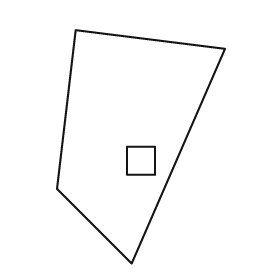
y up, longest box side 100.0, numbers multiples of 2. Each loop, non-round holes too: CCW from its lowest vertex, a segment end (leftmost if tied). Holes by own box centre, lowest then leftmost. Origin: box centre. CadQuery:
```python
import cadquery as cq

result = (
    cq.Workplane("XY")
    .moveTo(-4.0, -50.0)
    .lineTo(36.0, 42.0)
    .lineTo(-28.0, 50.0)
    .lineTo(-36.0, -18.0)
    .close()
    .moveTo(-6.0, -12.0)
    .lineTo(6.0, -12.0)
    .lineTo(6.0, 0.0)
    .lineTo(-6.0, 0.0)
    .close()
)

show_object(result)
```